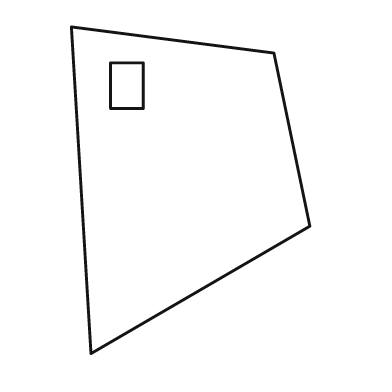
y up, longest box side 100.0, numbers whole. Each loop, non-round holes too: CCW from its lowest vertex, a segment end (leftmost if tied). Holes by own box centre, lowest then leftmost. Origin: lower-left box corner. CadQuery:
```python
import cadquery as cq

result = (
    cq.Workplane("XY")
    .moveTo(6.0, 0.0)
    .lineTo(73.0, 39.0)
    .lineTo(62.0, 92.0)
    .lineTo(0.0, 100.0)
    .close()
    .moveTo(12.0, 75.0)
    .lineTo(22.0, 75.0)
    .lineTo(22.0, 89.0)
    .lineTo(12.0, 89.0)
    .close()
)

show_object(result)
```